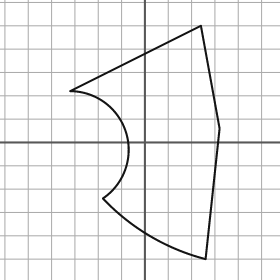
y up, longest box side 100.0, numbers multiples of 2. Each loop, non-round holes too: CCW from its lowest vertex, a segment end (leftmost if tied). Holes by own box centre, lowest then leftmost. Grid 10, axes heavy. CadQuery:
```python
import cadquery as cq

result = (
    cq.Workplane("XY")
    .moveTo(26.0, -50.0)
    .lineTo(32.0, 6.0)
    .lineTo(24.0, 50.0)
    .lineTo(-32.0, 22.0)
    .threePointArc((-8.0, 4.0), (-18.0, -24.0))
    .threePointArc((2.0, -40.0), (26.0, -50.0))
    .close()
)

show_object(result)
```